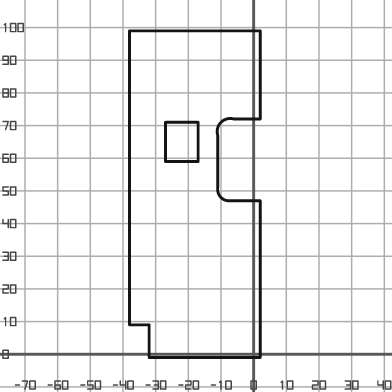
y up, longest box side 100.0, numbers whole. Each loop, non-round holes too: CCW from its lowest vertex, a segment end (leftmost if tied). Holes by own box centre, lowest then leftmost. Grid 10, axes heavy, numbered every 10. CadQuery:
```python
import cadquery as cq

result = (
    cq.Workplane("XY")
    .moveTo(-32.0, -1.0)
    .lineTo(2.0, -1.0)
    .lineTo(2.0, 47.0)
    .lineTo(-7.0, 47.0)
    .threePointArc((-10.0, 48.0), (-11.0, 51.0))
    .lineTo(-11.0, 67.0)
    .threePointArc((-10.0, 71.0), (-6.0, 72.0))
    .lineTo(2.0, 72.0)
    .lineTo(2.0, 99.0)
    .lineTo(-38.0, 99.0)
    .lineTo(-38.0, 9.0)
    .lineTo(-32.0, 9.0)
    .close()
    .moveTo(-27.0, 59.0)
    .lineTo(-17.0, 59.0)
    .lineTo(-17.0, 71.0)
    .lineTo(-27.0, 71.0)
    .close()
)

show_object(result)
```